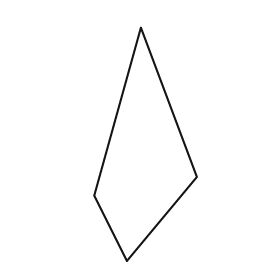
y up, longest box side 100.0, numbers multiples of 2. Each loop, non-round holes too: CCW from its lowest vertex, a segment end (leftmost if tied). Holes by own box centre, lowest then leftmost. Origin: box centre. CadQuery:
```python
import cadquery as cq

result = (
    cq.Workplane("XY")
    .moveTo(-8.0, -50.0)
    .lineTo(22.0, -14.0)
    .lineTo(-2.0, 50.0)
    .lineTo(-22.0, -22.0)
    .close()
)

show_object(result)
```